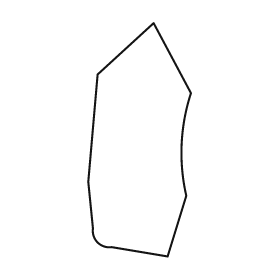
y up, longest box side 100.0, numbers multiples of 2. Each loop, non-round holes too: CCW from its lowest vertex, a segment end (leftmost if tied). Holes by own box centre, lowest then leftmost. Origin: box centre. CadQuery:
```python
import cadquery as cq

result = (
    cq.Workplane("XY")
    .moveTo(12.0, -50.0)
    .lineTo(20.0, -24.0)
    .threePointArc((18.0, -2.0), (22.0, 20.0))
    .lineTo(6.0, 50.0)
    .lineTo(-18.0, 28.0)
    .lineTo(-22.0, -18.0)
    .lineTo(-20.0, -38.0)
    .threePointArc((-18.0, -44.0), (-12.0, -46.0))
    .close()
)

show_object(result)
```